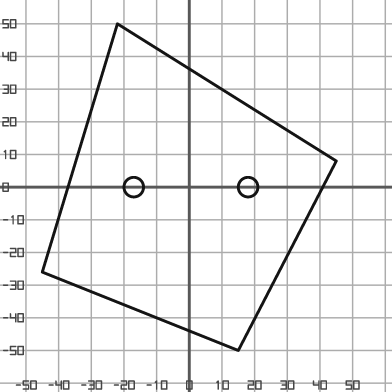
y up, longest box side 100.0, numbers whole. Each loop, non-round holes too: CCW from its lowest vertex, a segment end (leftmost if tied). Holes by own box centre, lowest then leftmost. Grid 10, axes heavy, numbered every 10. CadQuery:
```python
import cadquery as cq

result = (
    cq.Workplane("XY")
    .moveTo(15.0, -50.0)
    .lineTo(45.0, 8.0)
    .lineTo(-22.0, 50.0)
    .lineTo(-45.0, -26.0)
    .close()
    .moveTo(-17.0, 0.0)
    .circle(3.0)
    .moveTo(18.0, 0.0)
    .circle(3.0)
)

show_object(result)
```